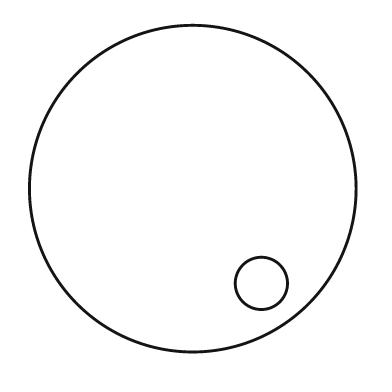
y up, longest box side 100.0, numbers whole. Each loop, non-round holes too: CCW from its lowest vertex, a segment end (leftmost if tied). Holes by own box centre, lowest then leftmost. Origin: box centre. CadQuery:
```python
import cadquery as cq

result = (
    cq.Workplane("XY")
    .moveTo(0.0, 0.0)
    .circle(50.0)
    .moveTo(21.0, -29.0)
    .circle(8.0)
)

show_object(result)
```